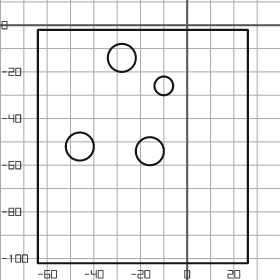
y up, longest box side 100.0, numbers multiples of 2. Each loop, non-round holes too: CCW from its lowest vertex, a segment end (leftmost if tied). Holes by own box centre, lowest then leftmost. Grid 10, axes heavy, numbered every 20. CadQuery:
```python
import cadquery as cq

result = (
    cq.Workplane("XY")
    .moveTo(-64.0, -102.0)
    .lineTo(26.0, -102.0)
    .lineTo(26.0, -2.0)
    .lineTo(-64.0, -2.0)
    .close()
    .moveTo(-16.0, -54.0)
    .circle(6.0)
    .moveTo(-46.0, -52.0)
    .circle(6.0)
    .moveTo(-10.0, -26.0)
    .circle(4.0)
    .moveTo(-28.0, -14.0)
    .circle(6.0)
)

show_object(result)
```